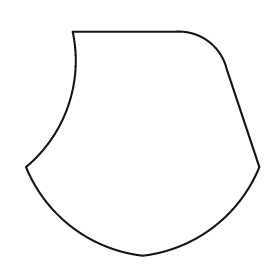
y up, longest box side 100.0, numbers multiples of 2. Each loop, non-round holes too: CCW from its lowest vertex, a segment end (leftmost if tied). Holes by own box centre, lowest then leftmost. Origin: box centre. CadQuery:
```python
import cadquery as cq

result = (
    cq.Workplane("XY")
    .moveTo(0.0, -48.0)
    .threePointArc((30.0, -36.0), (50.0, -10.0))
    .lineTo(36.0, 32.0)
    .threePointArc((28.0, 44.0), (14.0, 48.0))
    .lineTo(-30.0, 48.0)
    .threePointArc((-32.0, 16.0), (-50.0, -10.0))
    .threePointArc((-30.0, -36.0), (0.0, -48.0))
    .close()
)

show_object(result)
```